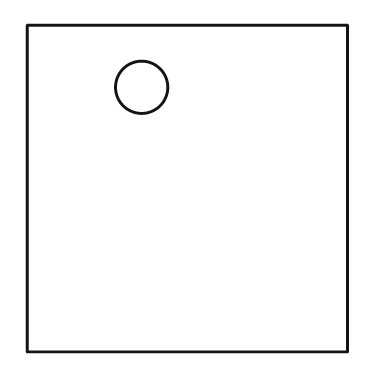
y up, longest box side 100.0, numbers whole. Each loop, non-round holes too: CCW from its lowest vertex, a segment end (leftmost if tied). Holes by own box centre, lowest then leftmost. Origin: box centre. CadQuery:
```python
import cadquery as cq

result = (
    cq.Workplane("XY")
    .moveTo(-49.0, -50.0)
    .lineTo(49.0, -50.0)
    .lineTo(49.0, 50.0)
    .lineTo(-49.0, 50.0)
    .close()
    .moveTo(-14.0, 31.0)
    .circle(8.0)
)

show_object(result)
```